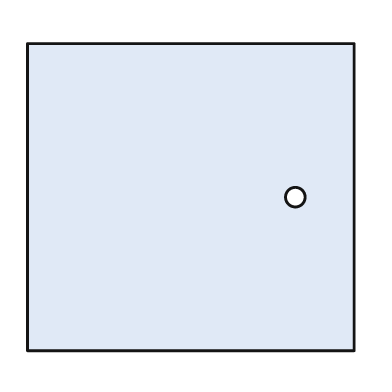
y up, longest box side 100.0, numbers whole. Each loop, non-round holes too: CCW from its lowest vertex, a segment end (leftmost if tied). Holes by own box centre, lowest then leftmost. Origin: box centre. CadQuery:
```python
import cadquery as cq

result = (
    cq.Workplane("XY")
    .moveTo(-50.0, -47.0)
    .lineTo(50.0, -47.0)
    .lineTo(50.0, 47.0)
    .lineTo(-50.0, 47.0)
    .close()
    .moveTo(32.0, 0.0)
    .circle(3.0)
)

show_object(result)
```